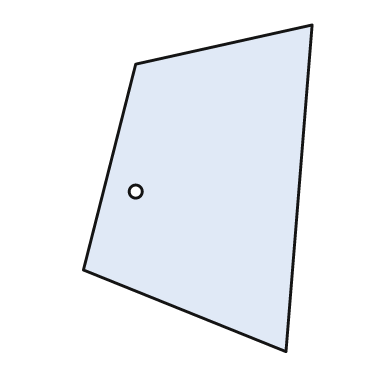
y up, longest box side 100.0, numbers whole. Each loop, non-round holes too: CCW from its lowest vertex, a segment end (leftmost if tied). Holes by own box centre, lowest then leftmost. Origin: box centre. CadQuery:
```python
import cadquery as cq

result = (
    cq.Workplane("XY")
    .moveTo(27.0, -50.0)
    .lineTo(35.0, 50.0)
    .lineTo(-19.0, 38.0)
    .lineTo(-35.0, -25.0)
    .close()
    .moveTo(-19.0, -1.0)
    .circle(2.0)
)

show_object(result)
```